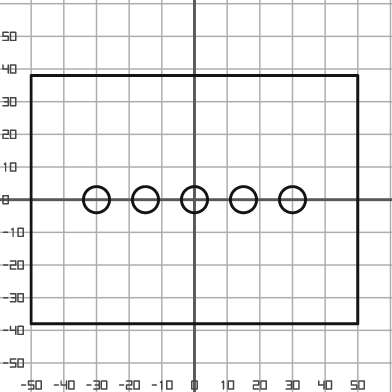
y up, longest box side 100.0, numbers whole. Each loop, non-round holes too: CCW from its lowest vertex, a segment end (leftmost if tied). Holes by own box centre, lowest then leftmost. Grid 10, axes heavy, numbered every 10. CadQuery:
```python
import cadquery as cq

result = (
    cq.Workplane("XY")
    .moveTo(-50.0, -38.0)
    .lineTo(50.0, -38.0)
    .lineTo(50.0, 38.0)
    .lineTo(-50.0, 38.0)
    .close()
    .moveTo(-30.0, 0.0)
    .circle(4.0)
    .moveTo(-15.0, 0.0)
    .circle(4.0)
    .moveTo(0.0, 0.0)
    .circle(4.0)
    .moveTo(15.0, 0.0)
    .circle(4.0)
    .moveTo(30.0, 0.0)
    .circle(4.0)
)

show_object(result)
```